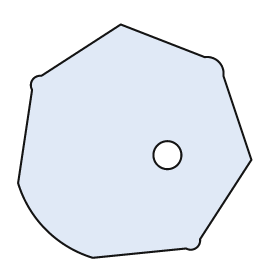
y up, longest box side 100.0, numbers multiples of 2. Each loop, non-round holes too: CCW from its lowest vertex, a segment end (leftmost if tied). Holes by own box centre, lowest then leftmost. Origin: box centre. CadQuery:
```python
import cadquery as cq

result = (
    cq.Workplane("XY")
    .moveTo(-18.0, -50.0)
    .lineTo(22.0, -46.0)
    .threePointArc((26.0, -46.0), (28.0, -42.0))
    .lineTo(50.0, -8.0)
    .lineTo(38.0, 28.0)
    .threePointArc((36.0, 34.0), (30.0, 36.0))
    .lineTo(-6.0, 50.0)
    .lineTo(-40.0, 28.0)
    .threePointArc((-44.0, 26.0), (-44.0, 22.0))
    .lineTo(-50.0, -18.0)
    .threePointArc((-38.0, -38.0), (-18.0, -50.0))
    .close()
    .moveTo(14.0, -6.0)
    .circle(6.0)
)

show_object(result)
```